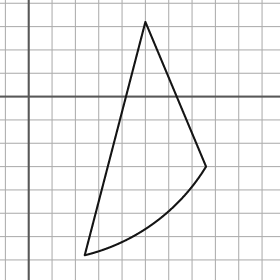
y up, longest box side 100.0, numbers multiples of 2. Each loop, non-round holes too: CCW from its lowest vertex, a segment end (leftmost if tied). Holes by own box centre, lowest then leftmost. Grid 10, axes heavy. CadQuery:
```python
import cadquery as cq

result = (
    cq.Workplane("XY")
    .moveTo(24.0, -68.0)
    .threePointArc((54.0, -54.0), (76.0, -30.0))
    .lineTo(50.0, 32.0)
    .close()
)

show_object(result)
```